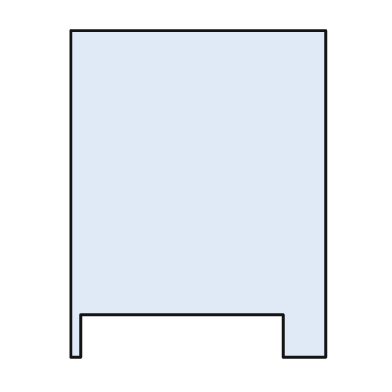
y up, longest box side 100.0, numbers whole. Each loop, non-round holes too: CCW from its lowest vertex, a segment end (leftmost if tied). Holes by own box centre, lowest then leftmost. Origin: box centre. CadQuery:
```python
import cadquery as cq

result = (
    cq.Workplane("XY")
    .moveTo(-39.0, -50.0)
    .lineTo(-36.0, -50.0)
    .lineTo(-36.0, -37.0)
    .lineTo(26.0, -37.0)
    .lineTo(26.0, -50.0)
    .lineTo(39.0, -50.0)
    .lineTo(39.0, 50.0)
    .lineTo(-39.0, 50.0)
    .close()
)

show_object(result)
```